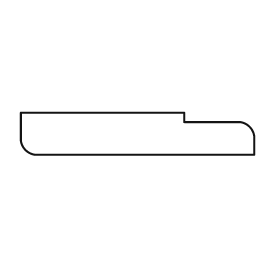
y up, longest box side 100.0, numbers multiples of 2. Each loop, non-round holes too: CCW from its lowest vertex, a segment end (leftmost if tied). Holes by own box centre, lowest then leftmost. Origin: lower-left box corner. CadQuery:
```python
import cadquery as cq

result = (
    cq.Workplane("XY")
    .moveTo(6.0, 0.0)
    .lineTo(100.0, 0.0)
    .lineTo(100.0, 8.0)
    .threePointArc((98.0, 12.0), (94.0, 14.0))
    .lineTo(70.0, 14.0)
    .lineTo(70.0, 18.0)
    .lineTo(0.0, 18.0)
    .lineTo(0.0, 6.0)
    .threePointArc((2.0, 2.0), (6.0, 0.0))
    .close()
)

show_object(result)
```